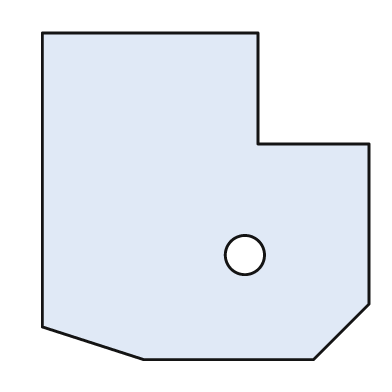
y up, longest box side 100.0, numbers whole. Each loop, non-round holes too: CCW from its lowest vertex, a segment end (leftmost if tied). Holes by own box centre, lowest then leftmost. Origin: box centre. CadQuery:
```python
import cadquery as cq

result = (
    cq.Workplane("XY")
    .moveTo(-19.0, -50.0)
    .lineTo(33.0, -50.0)
    .lineTo(50.0, -33.0)
    .lineTo(50.0, 16.0)
    .lineTo(16.0, 16.0)
    .lineTo(16.0, 50.0)
    .lineTo(-50.0, 50.0)
    .lineTo(-50.0, -40.0)
    .close()
    .moveTo(12.0, -18.0)
    .circle(6.0)
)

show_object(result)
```